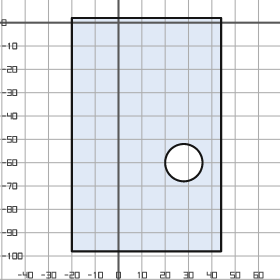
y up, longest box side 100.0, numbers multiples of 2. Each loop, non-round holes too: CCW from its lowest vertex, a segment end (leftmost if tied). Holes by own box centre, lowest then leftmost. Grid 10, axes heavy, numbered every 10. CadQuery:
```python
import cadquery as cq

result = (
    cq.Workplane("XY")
    .moveTo(-20.0, -98.0)
    .lineTo(44.0, -98.0)
    .lineTo(44.0, 2.0)
    .lineTo(-20.0, 2.0)
    .close()
    .moveTo(28.0, -60.0)
    .circle(8.0)
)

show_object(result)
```